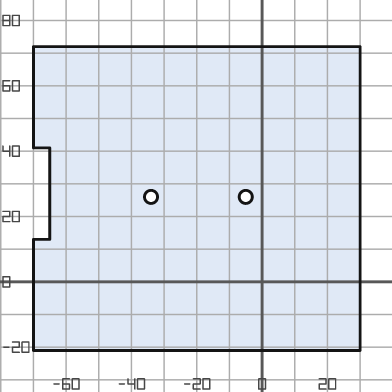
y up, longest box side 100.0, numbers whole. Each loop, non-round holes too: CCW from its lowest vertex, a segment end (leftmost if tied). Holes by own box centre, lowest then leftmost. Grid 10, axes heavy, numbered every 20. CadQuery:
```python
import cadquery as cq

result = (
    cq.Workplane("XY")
    .moveTo(-70.0, -21.0)
    .lineTo(30.0, -21.0)
    .lineTo(30.0, 72.0)
    .lineTo(-70.0, 72.0)
    .lineTo(-70.0, 41.0)
    .lineTo(-65.0, 41.0)
    .lineTo(-65.0, 13.0)
    .lineTo(-70.0, 13.0)
    .close()
    .moveTo(-34.0, 26.0)
    .circle(2.0)
    .moveTo(-5.0, 26.0)
    .circle(2.0)
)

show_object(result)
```